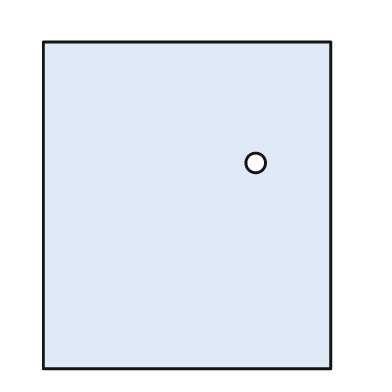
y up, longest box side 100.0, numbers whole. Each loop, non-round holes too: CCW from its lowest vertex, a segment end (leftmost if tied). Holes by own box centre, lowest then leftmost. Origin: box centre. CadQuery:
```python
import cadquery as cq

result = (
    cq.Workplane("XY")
    .moveTo(-44.0, -50.0)
    .lineTo(44.0, -50.0)
    .lineTo(44.0, 50.0)
    .lineTo(-44.0, 50.0)
    .close()
    .moveTo(21.0, 13.0)
    .circle(3.0)
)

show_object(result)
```